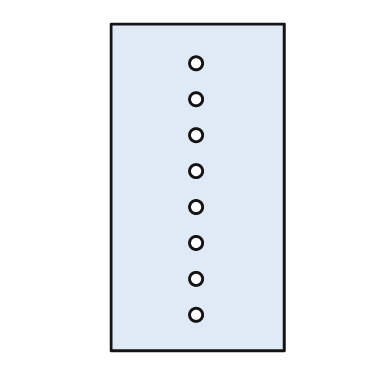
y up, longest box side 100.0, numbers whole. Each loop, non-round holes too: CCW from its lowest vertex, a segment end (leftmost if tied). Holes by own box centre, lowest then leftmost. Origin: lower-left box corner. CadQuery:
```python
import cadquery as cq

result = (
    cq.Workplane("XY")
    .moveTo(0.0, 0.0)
    .lineTo(53.0, 0.0)
    .lineTo(53.0, 100.0)
    .lineTo(0.0, 100.0)
    .close()
    .moveTo(26.0, 11.0)
    .circle(2.0)
    .moveTo(26.0, 22.0)
    .circle(2.0)
    .moveTo(26.0, 33.0)
    .circle(2.0)
    .moveTo(26.0, 44.0)
    .circle(2.0)
    .moveTo(26.0, 55.0)
    .circle(2.0)
    .moveTo(26.0, 66.0)
    .circle(2.0)
    .moveTo(26.0, 77.0)
    .circle(2.0)
    .moveTo(26.0, 88.0)
    .circle(2.0)
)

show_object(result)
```